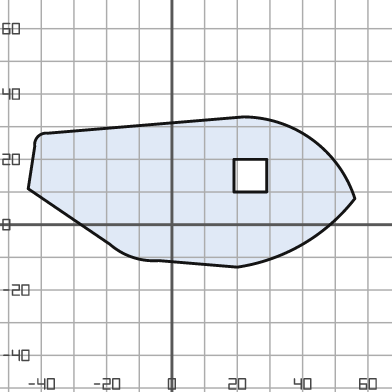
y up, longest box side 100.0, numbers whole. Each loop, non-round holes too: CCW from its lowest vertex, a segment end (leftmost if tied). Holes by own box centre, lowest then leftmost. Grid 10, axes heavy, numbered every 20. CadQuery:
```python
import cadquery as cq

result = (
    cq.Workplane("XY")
    .moveTo(20.0, -13.0)
    .threePointArc((40.0, -6.0), (56.0, 8.0))
    .threePointArc((43.0, 26.0), (22.0, 33.0))
    .lineTo(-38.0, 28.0)
    .threePointArc((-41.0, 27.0), (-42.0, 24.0))
    .lineTo(-44.0, 11.0)
    .lineTo(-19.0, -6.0)
    .threePointArc((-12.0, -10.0), (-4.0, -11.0))
    .close()
    .moveTo(19.0, 10.0)
    .lineTo(29.0, 10.0)
    .lineTo(29.0, 20.0)
    .lineTo(19.0, 20.0)
    .close()
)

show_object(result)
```